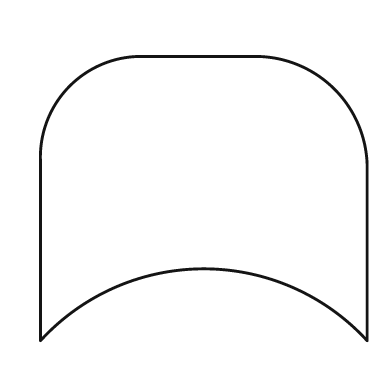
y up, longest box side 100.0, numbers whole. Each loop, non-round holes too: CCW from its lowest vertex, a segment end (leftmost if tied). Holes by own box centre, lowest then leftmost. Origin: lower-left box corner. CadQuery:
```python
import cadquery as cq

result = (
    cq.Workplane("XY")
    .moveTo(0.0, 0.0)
    .threePointArc((50.0, 22.0), (100.0, 0.0))
    .lineTo(100.0, 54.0)
    .threePointArc((90.0, 77.0), (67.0, 87.0))
    .lineTo(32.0, 87.0)
    .threePointArc((9.0, 78.0), (0.0, 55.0))
    .close()
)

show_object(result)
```